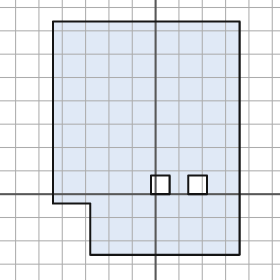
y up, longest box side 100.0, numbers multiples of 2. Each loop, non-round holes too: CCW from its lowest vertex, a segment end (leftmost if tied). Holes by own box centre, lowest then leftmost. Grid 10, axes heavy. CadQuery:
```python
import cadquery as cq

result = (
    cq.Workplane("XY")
    .moveTo(-28.0, -26.0)
    .lineTo(36.0, -26.0)
    .lineTo(36.0, 74.0)
    .lineTo(-44.0, 74.0)
    .lineTo(-44.0, -4.0)
    .lineTo(-28.0, -4.0)
    .close()
    .moveTo(-2.0, 0.0)
    .lineTo(6.0, 0.0)
    .lineTo(6.0, 8.0)
    .lineTo(-2.0, 8.0)
    .close()
    .moveTo(14.0, 0.0)
    .lineTo(22.0, 0.0)
    .lineTo(22.0, 8.0)
    .lineTo(14.0, 8.0)
    .close()
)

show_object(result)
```